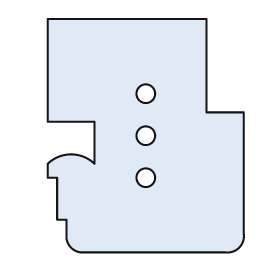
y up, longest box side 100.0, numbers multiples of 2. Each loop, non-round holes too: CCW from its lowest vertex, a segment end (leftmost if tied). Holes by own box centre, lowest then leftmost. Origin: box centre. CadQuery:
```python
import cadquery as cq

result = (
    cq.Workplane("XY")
    .moveTo(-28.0, -50.0)
    .lineTo(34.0, -50.0)
    .threePointArc((40.0, -48.0), (42.0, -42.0))
    .lineTo(42.0, 10.0)
    .lineTo(26.0, 10.0)
    .lineTo(26.0, 50.0)
    .lineTo(-42.0, 50.0)
    .lineTo(-42.0, 6.0)
    .lineTo(-22.0, 6.0)
    .lineTo(-22.0, -12.0)
    .threePointArc((-32.0, -8.0), (-42.0, -12.0))
    .lineTo(-42.0, -18.0)
    .lineTo(-38.0, -18.0)
    .lineTo(-38.0, -36.0)
    .lineTo(-34.0, -36.0)
    .lineTo(-34.0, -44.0)
    .threePointArc((-32.0, -48.0), (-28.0, -50.0))
    .close()
    .moveTo(0.0, -18.0)
    .circle(4.0)
    .moveTo(0.0, 0.0)
    .circle(4.0)
    .moveTo(0.0, 18.0)
    .circle(4.0)
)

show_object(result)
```